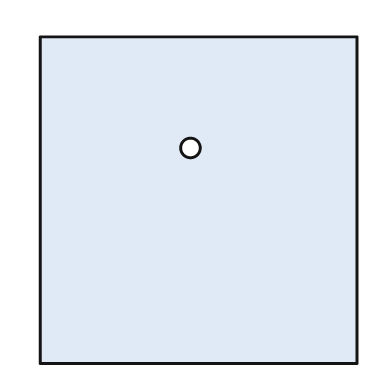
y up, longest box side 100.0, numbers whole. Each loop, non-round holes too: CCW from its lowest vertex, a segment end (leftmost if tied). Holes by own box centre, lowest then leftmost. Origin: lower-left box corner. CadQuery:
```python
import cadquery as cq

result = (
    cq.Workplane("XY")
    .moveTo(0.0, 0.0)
    .lineTo(97.0, 0.0)
    .lineTo(97.0, 100.0)
    .lineTo(0.0, 100.0)
    .close()
    .moveTo(46.0, 66.0)
    .circle(3.0)
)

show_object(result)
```